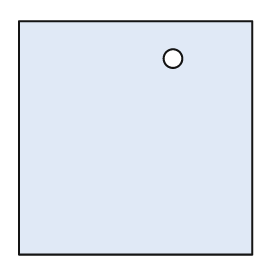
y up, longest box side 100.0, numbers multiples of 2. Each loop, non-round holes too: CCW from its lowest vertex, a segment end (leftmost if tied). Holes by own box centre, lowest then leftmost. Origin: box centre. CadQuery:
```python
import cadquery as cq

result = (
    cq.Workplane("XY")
    .moveTo(-50.0, -50.0)
    .lineTo(50.0, -50.0)
    .lineTo(50.0, 50.0)
    .lineTo(-50.0, 50.0)
    .close()
    .moveTo(16.0, 34.0)
    .circle(4.0)
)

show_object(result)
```